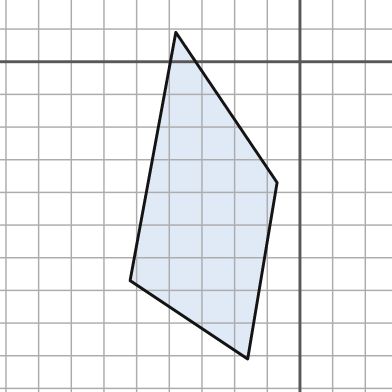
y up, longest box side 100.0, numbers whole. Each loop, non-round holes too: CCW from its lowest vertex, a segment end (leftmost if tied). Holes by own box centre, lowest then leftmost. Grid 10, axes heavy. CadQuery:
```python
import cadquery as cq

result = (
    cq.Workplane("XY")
    .moveTo(-16.0, -91.0)
    .lineTo(-7.0, -37.0)
    .lineTo(-38.0, 9.0)
    .lineTo(-52.0, -67.0)
    .close()
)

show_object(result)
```